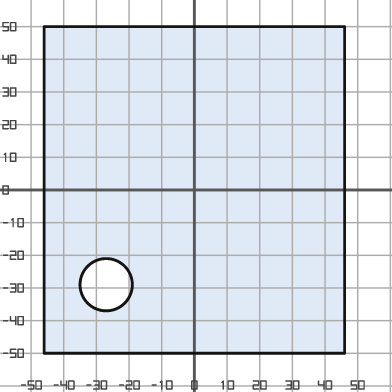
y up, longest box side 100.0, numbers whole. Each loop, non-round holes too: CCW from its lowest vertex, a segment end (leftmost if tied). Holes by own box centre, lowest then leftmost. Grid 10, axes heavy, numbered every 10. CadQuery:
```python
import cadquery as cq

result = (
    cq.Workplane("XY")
    .moveTo(-46.0, -50.0)
    .lineTo(46.0, -50.0)
    .lineTo(46.0, 50.0)
    .lineTo(-46.0, 50.0)
    .close()
    .moveTo(-27.0, -29.0)
    .circle(8.0)
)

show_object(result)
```